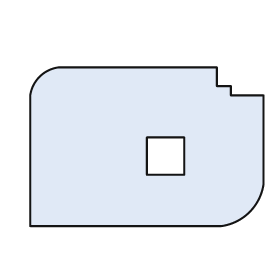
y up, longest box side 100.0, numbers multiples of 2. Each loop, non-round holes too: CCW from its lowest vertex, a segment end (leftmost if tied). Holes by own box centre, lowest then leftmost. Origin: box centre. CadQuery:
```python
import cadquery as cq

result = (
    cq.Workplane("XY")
    .moveTo(-50.0, -34.0)
    .lineTo(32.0, -34.0)
    .threePointArc((44.0, -28.0), (50.0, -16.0))
    .lineTo(50.0, 22.0)
    .lineTo(36.0, 22.0)
    .lineTo(36.0, 26.0)
    .lineTo(30.0, 26.0)
    .lineTo(30.0, 34.0)
    .lineTo(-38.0, 34.0)
    .threePointArc((-46.0, 30.0), (-50.0, 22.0))
    .close()
    .moveTo(0.0, -12.0)
    .lineTo(16.0, -12.0)
    .lineTo(16.0, 4.0)
    .lineTo(0.0, 4.0)
    .close()
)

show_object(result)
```